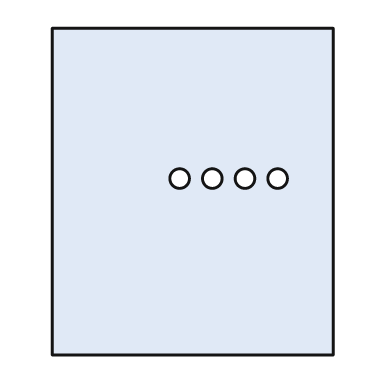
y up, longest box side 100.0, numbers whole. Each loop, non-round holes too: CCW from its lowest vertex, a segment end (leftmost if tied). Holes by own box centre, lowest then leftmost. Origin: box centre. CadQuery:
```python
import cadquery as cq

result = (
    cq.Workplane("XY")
    .moveTo(-43.0, -50.0)
    .lineTo(43.0, -50.0)
    .lineTo(43.0, 50.0)
    .lineTo(-43.0, 50.0)
    .close()
    .moveTo(-4.0, 4.0)
    .circle(3.0)
    .moveTo(6.0, 4.0)
    .circle(3.0)
    .moveTo(16.0, 4.0)
    .circle(3.0)
    .moveTo(26.0, 4.0)
    .circle(3.0)
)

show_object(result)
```